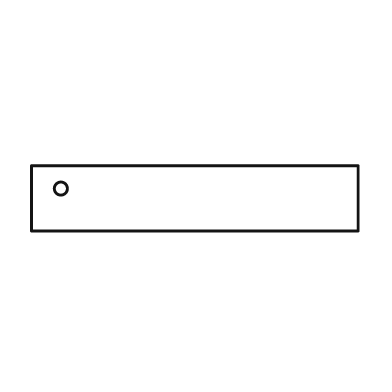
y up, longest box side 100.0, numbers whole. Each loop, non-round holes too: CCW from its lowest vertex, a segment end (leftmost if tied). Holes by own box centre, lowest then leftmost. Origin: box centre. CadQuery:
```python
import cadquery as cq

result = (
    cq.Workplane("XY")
    .moveTo(-50.0, -10.0)
    .lineTo(50.0, -10.0)
    .lineTo(50.0, 10.0)
    .lineTo(-50.0, 10.0)
    .close()
    .moveTo(-41.0, 3.0)
    .circle(2.0)
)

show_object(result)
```